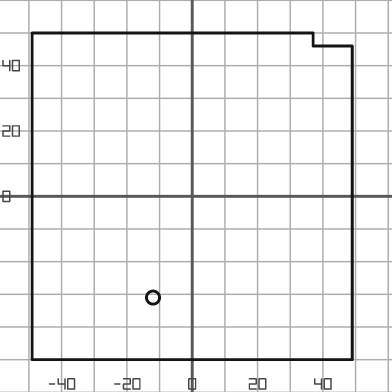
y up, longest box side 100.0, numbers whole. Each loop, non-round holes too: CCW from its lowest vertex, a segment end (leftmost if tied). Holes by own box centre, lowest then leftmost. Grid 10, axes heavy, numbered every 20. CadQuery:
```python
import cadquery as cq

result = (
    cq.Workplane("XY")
    .moveTo(-49.0, -50.0)
    .lineTo(49.0, -50.0)
    .lineTo(49.0, 46.0)
    .lineTo(37.0, 46.0)
    .lineTo(37.0, 50.0)
    .lineTo(-49.0, 50.0)
    .close()
    .moveTo(-12.0, -31.0)
    .circle(2.0)
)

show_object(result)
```